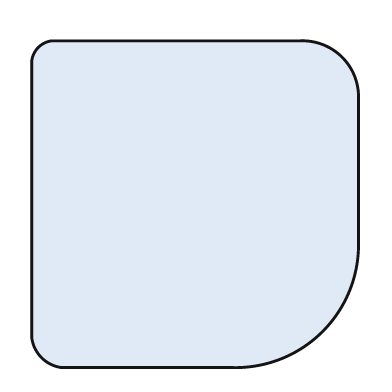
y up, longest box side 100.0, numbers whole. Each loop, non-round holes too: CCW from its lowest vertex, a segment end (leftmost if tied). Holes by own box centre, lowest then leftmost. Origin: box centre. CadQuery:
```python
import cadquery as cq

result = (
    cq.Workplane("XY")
    .moveTo(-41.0, -50.0)
    .lineTo(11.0, -50.0)
    .threePointArc((39.0, -39.0), (50.0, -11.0))
    .lineTo(50.0, 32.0)
    .threePointArc((45.0, 45.0), (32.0, 50.0))
    .lineTo(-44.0, 50.0)
    .threePointArc((-48.0, 48.0), (-50.0, 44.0))
    .lineTo(-50.0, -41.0)
    .threePointArc((-47.0, -47.0), (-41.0, -50.0))
    .close()
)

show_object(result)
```